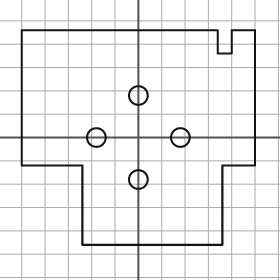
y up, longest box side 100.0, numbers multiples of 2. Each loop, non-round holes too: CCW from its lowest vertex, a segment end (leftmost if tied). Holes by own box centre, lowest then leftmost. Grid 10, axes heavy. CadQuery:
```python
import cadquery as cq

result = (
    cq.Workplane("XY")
    .moveTo(-24.0, -46.0)
    .lineTo(36.0, -46.0)
    .lineTo(36.0, -12.0)
    .lineTo(50.0, -12.0)
    .lineTo(50.0, 46.0)
    .lineTo(40.0, 46.0)
    .lineTo(40.0, 36.0)
    .lineTo(34.0, 36.0)
    .lineTo(34.0, 46.0)
    .lineTo(-50.0, 46.0)
    .lineTo(-50.0, -12.0)
    .lineTo(-24.0, -12.0)
    .close()
    .moveTo(0.0, -18.0)
    .circle(4.0)
    .moveTo(-18.0, 0.0)
    .circle(4.0)
    .moveTo(18.0, 0.0)
    .circle(4.0)
    .moveTo(0.0, 18.0)
    .circle(4.0)
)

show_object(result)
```